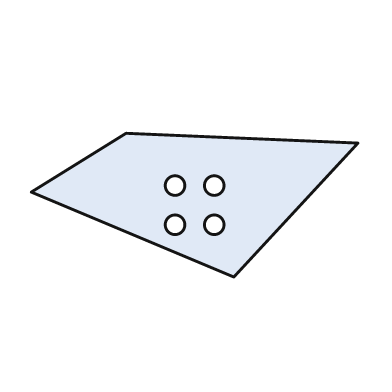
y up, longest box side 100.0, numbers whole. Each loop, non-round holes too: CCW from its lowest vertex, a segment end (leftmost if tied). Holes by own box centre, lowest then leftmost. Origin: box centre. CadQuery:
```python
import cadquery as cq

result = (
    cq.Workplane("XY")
    .moveTo(12.0, -22.0)
    .lineTo(50.0, 19.0)
    .lineTo(-21.0, 22.0)
    .lineTo(-50.0, 4.0)
    .close()
    .moveTo(-6.0, -6.0)
    .circle(3.0)
    .moveTo(6.0, -6.0)
    .circle(3.0)
    .moveTo(-6.0, 6.0)
    .circle(3.0)
    .moveTo(6.0, 6.0)
    .circle(3.0)
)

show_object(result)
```